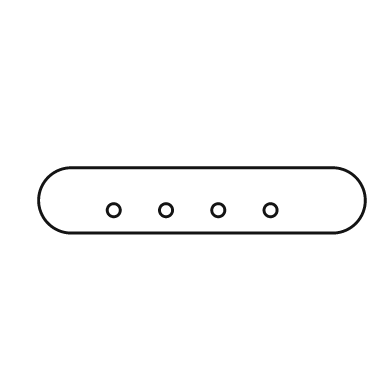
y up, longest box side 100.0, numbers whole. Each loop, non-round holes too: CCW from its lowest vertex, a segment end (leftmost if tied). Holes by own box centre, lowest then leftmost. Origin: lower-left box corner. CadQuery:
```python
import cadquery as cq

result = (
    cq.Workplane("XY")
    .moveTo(10.0, 0.0)
    .lineTo(90.0, 0.0)
    .threePointArc((100.0, 10.0), (90.0, 20.0))
    .lineTo(10.0, 20.0)
    .threePointArc((0.0, 10.0), (10.0, 0.0))
    .close()
    .moveTo(23.0, 7.0)
    .circle(2.0)
    .moveTo(39.0, 7.0)
    .circle(2.0)
    .moveTo(55.0, 7.0)
    .circle(2.0)
    .moveTo(71.0, 7.0)
    .circle(2.0)
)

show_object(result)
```